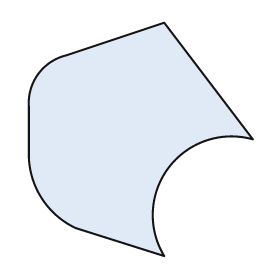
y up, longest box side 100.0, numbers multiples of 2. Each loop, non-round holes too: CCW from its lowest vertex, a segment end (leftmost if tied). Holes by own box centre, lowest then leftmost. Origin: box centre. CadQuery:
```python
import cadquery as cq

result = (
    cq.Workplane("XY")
    .moveTo(10.0, -50.0)
    .threePointArc((12.0, -12.0), (48.0, 0.0))
    .lineTo(10.0, 50.0)
    .lineTo(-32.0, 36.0)
    .threePointArc((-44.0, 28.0), (-48.0, 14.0))
    .lineTo(-48.0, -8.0)
    .threePointArc((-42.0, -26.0), (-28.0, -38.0))
    .close()
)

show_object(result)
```